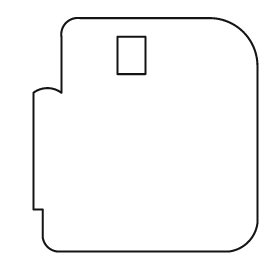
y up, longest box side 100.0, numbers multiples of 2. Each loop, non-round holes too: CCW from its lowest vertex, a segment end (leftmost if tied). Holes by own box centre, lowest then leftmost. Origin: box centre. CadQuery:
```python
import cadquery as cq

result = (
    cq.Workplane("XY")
    .moveTo(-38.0, -50.0)
    .lineTo(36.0, -50.0)
    .threePointArc((44.0, -46.0), (48.0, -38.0))
    .lineTo(48.0, 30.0)
    .threePointArc((42.0, 44.0), (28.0, 50.0))
    .lineTo(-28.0, 50.0)
    .threePointArc((-34.0, 48.0), (-36.0, 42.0))
    .lineTo(-36.0, 18.0)
    .threePointArc((-42.0, 20.0), (-48.0, 18.0))
    .lineTo(-48.0, -32.0)
    .lineTo(-44.0, -32.0)
    .lineTo(-44.0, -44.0)
    .threePointArc((-42.0, -48.0), (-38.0, -50.0))
    .close()
    .moveTo(-12.0, 26.0)
    .lineTo(0.0, 26.0)
    .lineTo(0.0, 42.0)
    .lineTo(-12.0, 42.0)
    .close()
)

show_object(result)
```